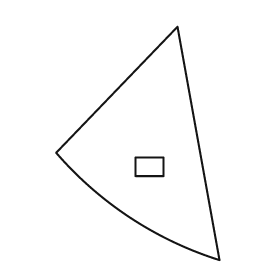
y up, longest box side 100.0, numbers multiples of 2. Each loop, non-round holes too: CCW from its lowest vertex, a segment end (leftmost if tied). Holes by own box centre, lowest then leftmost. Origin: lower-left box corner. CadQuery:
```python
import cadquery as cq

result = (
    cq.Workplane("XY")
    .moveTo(70.0, 0.0)
    .lineTo(52.0, 100.0)
    .lineTo(0.0, 46.0)
    .threePointArc((32.0, 18.0), (70.0, 0.0))
    .close()
    .moveTo(34.0, 36.0)
    .lineTo(46.0, 36.0)
    .lineTo(46.0, 44.0)
    .lineTo(34.0, 44.0)
    .close()
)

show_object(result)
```